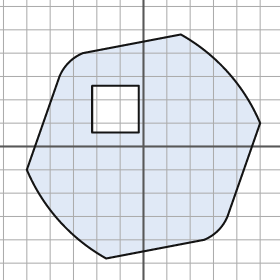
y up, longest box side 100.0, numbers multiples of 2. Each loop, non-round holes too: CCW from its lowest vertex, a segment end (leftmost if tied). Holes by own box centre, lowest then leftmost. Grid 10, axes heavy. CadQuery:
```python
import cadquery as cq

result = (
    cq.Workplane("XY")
    .moveTo(-16.0, -48.0)
    .lineTo(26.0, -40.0)
    .threePointArc((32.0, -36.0), (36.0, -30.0))
    .lineTo(50.0, 10.0)
    .threePointArc((36.0, 32.0), (16.0, 48.0))
    .lineTo(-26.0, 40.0)
    .threePointArc((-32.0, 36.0), (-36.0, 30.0))
    .lineTo(-50.0, -10.0)
    .threePointArc((-36.0, -32.0), (-16.0, -48.0))
    .close()
    .moveTo(-22.0, 6.0)
    .lineTo(-2.0, 6.0)
    .lineTo(-2.0, 26.0)
    .lineTo(-22.0, 26.0)
    .close()
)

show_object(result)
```